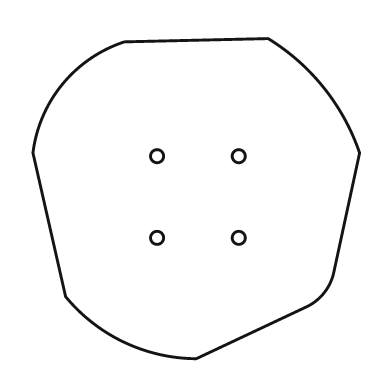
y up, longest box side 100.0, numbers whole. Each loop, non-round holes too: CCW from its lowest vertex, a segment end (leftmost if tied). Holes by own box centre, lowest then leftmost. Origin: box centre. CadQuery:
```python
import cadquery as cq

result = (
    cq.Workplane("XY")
    .moveTo(0.0, -49.0)
    .lineTo(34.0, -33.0)
    .threePointArc((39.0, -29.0), (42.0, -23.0))
    .lineTo(50.0, 14.0)
    .threePointArc((39.0, 34.0), (22.0, 49.0))
    .lineTo(-22.0, 48.0)
    .threePointArc((-41.0, 35.0), (-50.0, 14.0))
    .lineTo(-40.0, -30.0)
    .threePointArc((-22.0, -44.0), (0.0, -49.0))
    .close()
    .moveTo(-12.0, -12.0)
    .circle(2.0)
    .moveTo(13.0, -12.0)
    .circle(2.0)
    .moveTo(-12.0, 13.0)
    .circle(2.0)
    .moveTo(13.0, 13.0)
    .circle(2.0)
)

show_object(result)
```